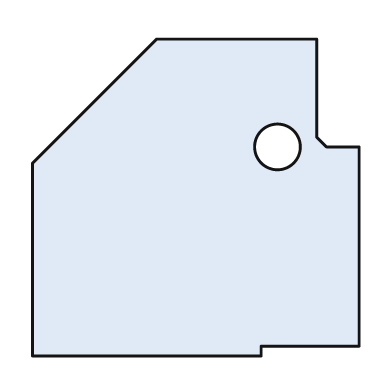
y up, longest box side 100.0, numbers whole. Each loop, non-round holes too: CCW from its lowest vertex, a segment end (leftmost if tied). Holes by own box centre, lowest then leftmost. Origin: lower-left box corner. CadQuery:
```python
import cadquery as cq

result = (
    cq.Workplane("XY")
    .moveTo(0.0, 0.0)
    .lineTo(70.0, 0.0)
    .lineTo(70.0, 3.0)
    .lineTo(100.0, 3.0)
    .lineTo(100.0, 64.0)
    .lineTo(90.0, 64.0)
    .lineTo(87.0, 67.0)
    .lineTo(87.0, 97.0)
    .lineTo(38.0, 97.0)
    .lineTo(0.0, 59.0)
    .close()
    .moveTo(75.0, 64.0)
    .circle(7.0)
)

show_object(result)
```